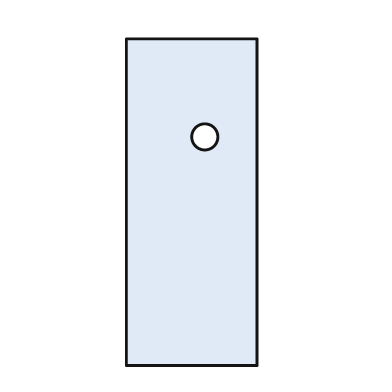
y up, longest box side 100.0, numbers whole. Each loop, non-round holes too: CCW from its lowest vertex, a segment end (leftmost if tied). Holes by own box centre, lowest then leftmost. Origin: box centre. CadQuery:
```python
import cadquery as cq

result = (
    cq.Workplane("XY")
    .moveTo(-20.0, -50.0)
    .lineTo(20.0, -50.0)
    .lineTo(20.0, 50.0)
    .lineTo(-20.0, 50.0)
    .close()
    .moveTo(4.0, 20.0)
    .circle(4.0)
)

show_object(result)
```